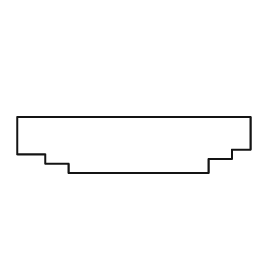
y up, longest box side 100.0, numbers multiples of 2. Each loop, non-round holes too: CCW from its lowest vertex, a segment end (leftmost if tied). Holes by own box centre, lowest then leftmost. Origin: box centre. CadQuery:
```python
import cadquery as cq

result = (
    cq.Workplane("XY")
    .moveTo(-28.0, -12.0)
    .lineTo(32.0, -12.0)
    .lineTo(32.0, -6.0)
    .lineTo(42.0, -6.0)
    .lineTo(42.0, -2.0)
    .lineTo(50.0, -2.0)
    .lineTo(50.0, 12.0)
    .lineTo(-50.0, 12.0)
    .lineTo(-50.0, -4.0)
    .lineTo(-38.0, -4.0)
    .lineTo(-38.0, -8.0)
    .lineTo(-28.0, -8.0)
    .close()
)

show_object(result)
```